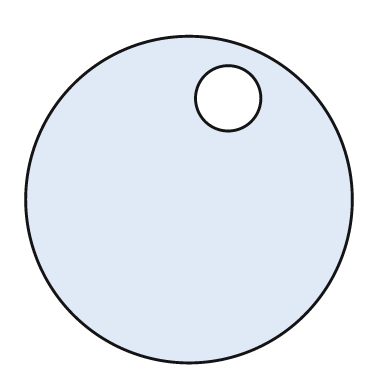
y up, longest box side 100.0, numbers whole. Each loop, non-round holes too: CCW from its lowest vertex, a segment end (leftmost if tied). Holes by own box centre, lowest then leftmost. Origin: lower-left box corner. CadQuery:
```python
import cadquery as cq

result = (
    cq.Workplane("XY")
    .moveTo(50.0, 50.0)
    .circle(50.0)
    .moveTo(62.0, 81.0)
    .circle(10.0)
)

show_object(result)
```